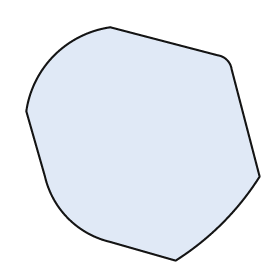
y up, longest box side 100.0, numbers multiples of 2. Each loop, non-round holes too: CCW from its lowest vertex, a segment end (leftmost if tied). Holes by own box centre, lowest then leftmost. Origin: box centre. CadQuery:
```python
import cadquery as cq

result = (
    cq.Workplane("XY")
    .moveTo(14.0, -50.0)
    .threePointArc((34.0, -34.0), (50.0, -14.0))
    .lineTo(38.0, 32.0)
    .threePointArc((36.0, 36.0), (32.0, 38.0))
    .lineTo(-14.0, 50.0)
    .threePointArc((-38.0, 38.0), (-50.0, 14.0))
    .lineTo(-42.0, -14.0)
    .threePointArc((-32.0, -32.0), (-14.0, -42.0))
    .close()
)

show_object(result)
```